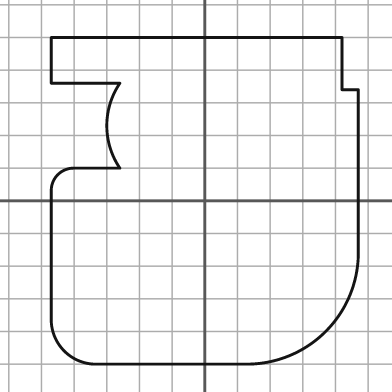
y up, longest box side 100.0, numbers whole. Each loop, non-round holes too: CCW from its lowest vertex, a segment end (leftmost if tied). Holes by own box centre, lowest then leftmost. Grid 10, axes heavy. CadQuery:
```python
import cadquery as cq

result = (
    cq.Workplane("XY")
    .moveTo(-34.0, -50.0)
    .lineTo(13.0, -50.0)
    .threePointArc((37.0, -40.0), (47.0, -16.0))
    .lineTo(47.0, 34.0)
    .lineTo(42.0, 34.0)
    .lineTo(42.0, 50.0)
    .lineTo(-47.0, 50.0)
    .lineTo(-47.0, 36.0)
    .lineTo(-26.0, 36.0)
    .threePointArc((-30.0, 23.0), (-26.0, 10.0))
    .lineTo(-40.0, 10.0)
    .threePointArc((-45.0, 8.0), (-47.0, 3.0))
    .lineTo(-47.0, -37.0)
    .threePointArc((-43.0, -46.0), (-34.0, -50.0))
    .close()
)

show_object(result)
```